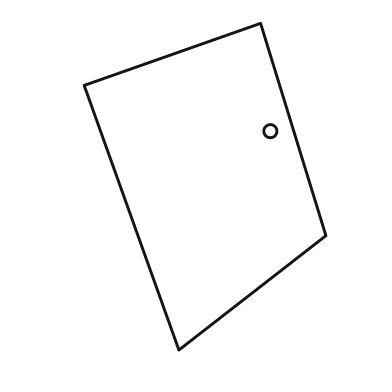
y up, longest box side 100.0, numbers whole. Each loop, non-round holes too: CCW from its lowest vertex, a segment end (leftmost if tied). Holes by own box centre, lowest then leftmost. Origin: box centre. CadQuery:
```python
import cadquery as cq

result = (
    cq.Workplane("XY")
    .moveTo(-8.0, -50.0)
    .lineTo(37.0, -15.0)
    .lineTo(17.0, 50.0)
    .lineTo(-37.0, 31.0)
    .close()
    .moveTo(20.0, 17.0)
    .circle(2.0)
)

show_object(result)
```